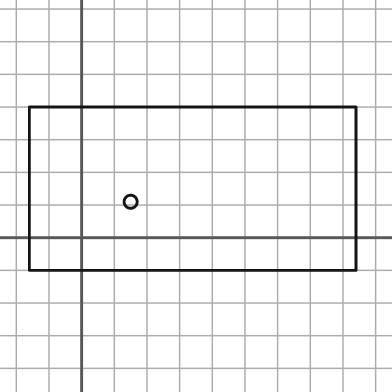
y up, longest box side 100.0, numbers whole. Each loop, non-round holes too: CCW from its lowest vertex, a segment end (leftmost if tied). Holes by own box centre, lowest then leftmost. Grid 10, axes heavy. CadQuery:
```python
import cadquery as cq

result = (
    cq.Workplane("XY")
    .moveTo(-16.0, -10.0)
    .lineTo(84.0, -10.0)
    .lineTo(84.0, 40.0)
    .lineTo(-16.0, 40.0)
    .close()
    .moveTo(15.0, 11.0)
    .circle(2.0)
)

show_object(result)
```